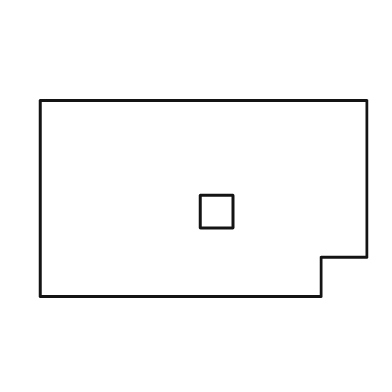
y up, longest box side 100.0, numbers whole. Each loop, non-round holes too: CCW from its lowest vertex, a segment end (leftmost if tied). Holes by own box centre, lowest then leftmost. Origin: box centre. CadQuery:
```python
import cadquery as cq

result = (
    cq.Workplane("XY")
    .moveTo(-50.0, -30.0)
    .lineTo(36.0, -30.0)
    .lineTo(36.0, -18.0)
    .lineTo(50.0, -18.0)
    .lineTo(50.0, 30.0)
    .lineTo(-50.0, 30.0)
    .close()
    .moveTo(-1.0, -9.0)
    .lineTo(9.0, -9.0)
    .lineTo(9.0, 1.0)
    .lineTo(-1.0, 1.0)
    .close()
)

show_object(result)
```